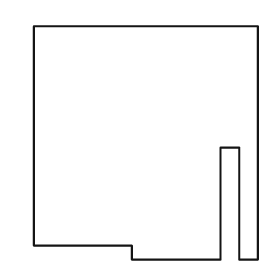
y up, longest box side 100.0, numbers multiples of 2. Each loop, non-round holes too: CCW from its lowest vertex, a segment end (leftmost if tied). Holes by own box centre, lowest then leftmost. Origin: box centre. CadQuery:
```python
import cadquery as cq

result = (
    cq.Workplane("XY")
    .moveTo(-6.0, -50.0)
    .lineTo(32.0, -50.0)
    .lineTo(32.0, -2.0)
    .lineTo(40.0, -2.0)
    .lineTo(40.0, -50.0)
    .lineTo(48.0, -50.0)
    .lineTo(48.0, 50.0)
    .lineTo(-48.0, 50.0)
    .lineTo(-48.0, -44.0)
    .lineTo(-6.0, -44.0)
    .close()
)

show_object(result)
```